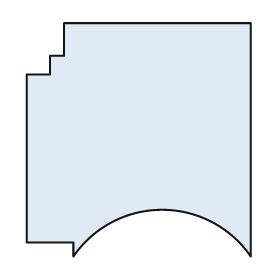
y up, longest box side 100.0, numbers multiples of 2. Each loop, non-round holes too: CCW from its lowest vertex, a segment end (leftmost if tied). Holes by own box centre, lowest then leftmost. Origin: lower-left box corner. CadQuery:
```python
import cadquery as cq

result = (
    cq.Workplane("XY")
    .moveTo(20.0, 0.0)
    .threePointArc((58.0, 20.0), (96.0, 0.0))
    .lineTo(96.0, 100.0)
    .lineTo(16.0, 100.0)
    .lineTo(16.0, 86.0)
    .lineTo(10.0, 86.0)
    .lineTo(10.0, 78.0)
    .lineTo(0.0, 78.0)
    .lineTo(0.0, 6.0)
    .lineTo(20.0, 6.0)
    .close()
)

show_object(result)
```